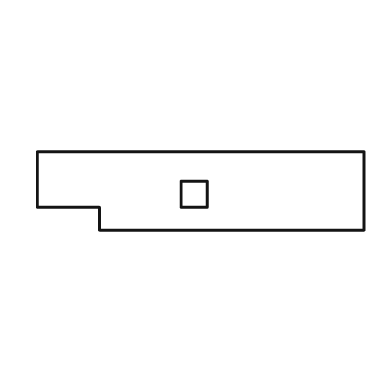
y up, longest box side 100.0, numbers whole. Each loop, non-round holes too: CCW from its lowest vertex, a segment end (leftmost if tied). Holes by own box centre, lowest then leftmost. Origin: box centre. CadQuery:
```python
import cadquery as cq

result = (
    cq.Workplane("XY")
    .moveTo(-31.0, -12.0)
    .lineTo(50.0, -12.0)
    .lineTo(50.0, 12.0)
    .lineTo(-50.0, 12.0)
    .lineTo(-50.0, -5.0)
    .lineTo(-31.0, -5.0)
    .close()
    .moveTo(-6.0, -5.0)
    .lineTo(2.0, -5.0)
    .lineTo(2.0, 3.0)
    .lineTo(-6.0, 3.0)
    .close()
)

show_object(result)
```